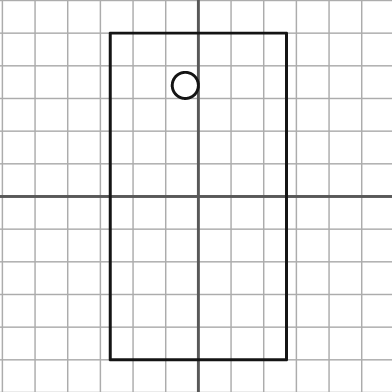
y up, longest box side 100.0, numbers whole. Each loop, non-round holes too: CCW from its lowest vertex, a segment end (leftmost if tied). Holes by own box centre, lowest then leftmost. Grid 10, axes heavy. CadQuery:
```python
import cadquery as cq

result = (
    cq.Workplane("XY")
    .moveTo(-27.0, -50.0)
    .lineTo(27.0, -50.0)
    .lineTo(27.0, 50.0)
    .lineTo(-27.0, 50.0)
    .close()
    .moveTo(-4.0, 34.0)
    .circle(4.0)
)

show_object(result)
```